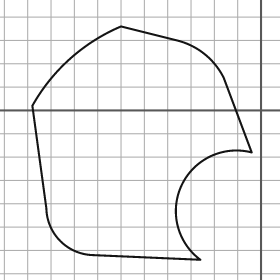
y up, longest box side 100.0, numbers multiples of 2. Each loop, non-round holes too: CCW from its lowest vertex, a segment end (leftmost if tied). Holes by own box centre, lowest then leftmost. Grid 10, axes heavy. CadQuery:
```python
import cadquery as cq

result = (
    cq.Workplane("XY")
    .moveTo(-26.0, -64.0)
    .threePointArc((-34.0, -32.0), (-4.0, -18.0))
    .lineTo(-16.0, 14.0)
    .threePointArc((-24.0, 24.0), (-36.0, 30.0))
    .lineTo(-60.0, 36.0)
    .threePointArc((-82.0, 22.0), (-98.0, 2.0))
    .lineTo(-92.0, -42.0)
    .threePointArc((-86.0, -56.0), (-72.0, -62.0))
    .close()
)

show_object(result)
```